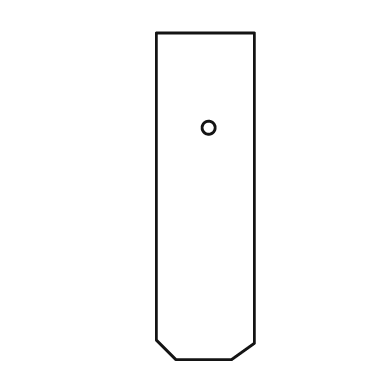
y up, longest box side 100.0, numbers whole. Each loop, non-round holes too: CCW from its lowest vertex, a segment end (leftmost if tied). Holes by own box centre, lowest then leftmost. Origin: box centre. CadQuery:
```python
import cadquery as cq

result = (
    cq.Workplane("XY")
    .moveTo(-9.0, -50.0)
    .lineTo(8.0, -50.0)
    .lineTo(15.0, -45.0)
    .lineTo(15.0, 50.0)
    .lineTo(-15.0, 50.0)
    .lineTo(-15.0, -44.0)
    .close()
    .moveTo(1.0, 21.0)
    .circle(2.0)
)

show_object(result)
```